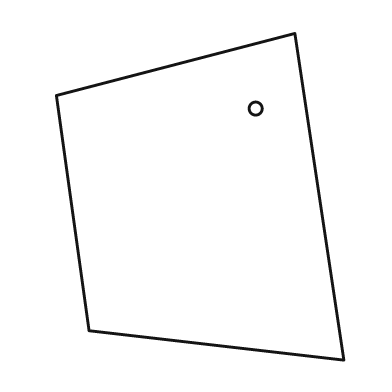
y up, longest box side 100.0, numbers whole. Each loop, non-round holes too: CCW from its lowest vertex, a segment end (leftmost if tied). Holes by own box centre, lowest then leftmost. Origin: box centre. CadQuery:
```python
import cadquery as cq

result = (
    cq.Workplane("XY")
    .moveTo(44.0, -50.0)
    .lineTo(29.0, 50.0)
    .lineTo(-44.0, 31.0)
    .lineTo(-34.0, -41.0)
    .close()
    .moveTo(17.0, 27.0)
    .circle(2.0)
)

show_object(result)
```